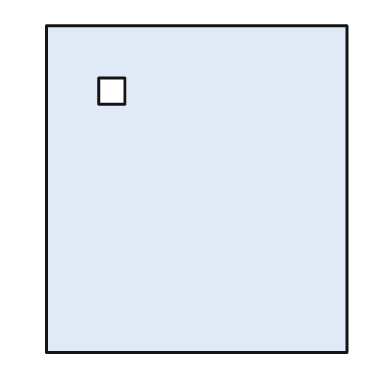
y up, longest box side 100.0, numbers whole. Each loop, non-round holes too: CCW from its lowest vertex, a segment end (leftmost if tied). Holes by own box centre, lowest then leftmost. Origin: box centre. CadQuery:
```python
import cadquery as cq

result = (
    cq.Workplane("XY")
    .moveTo(-46.0, -50.0)
    .lineTo(46.0, -50.0)
    .lineTo(46.0, 50.0)
    .lineTo(-46.0, 50.0)
    .close()
    .moveTo(-30.0, 26.0)
    .lineTo(-22.0, 26.0)
    .lineTo(-22.0, 34.0)
    .lineTo(-30.0, 34.0)
    .close()
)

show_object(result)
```